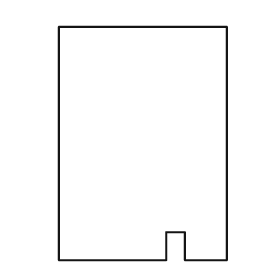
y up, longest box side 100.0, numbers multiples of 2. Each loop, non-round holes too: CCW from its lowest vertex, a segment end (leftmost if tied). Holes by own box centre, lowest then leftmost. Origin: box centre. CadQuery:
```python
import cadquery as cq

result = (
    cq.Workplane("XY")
    .moveTo(-36.0, -50.0)
    .lineTo(10.0, -50.0)
    .lineTo(10.0, -38.0)
    .lineTo(18.0, -38.0)
    .lineTo(18.0, -50.0)
    .lineTo(36.0, -50.0)
    .lineTo(36.0, 50.0)
    .lineTo(-36.0, 50.0)
    .close()
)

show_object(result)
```